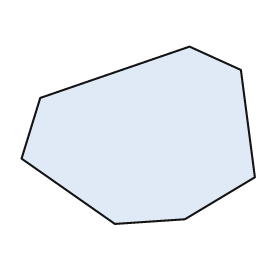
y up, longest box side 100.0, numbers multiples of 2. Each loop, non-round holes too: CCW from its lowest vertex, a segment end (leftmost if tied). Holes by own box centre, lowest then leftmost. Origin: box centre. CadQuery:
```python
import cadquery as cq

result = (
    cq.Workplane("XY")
    .moveTo(-10.0, -38.0)
    .lineTo(20.0, -36.0)
    .lineTo(50.0, -18.0)
    .lineTo(44.0, 28.0)
    .lineTo(22.0, 38.0)
    .lineTo(-42.0, 16.0)
    .lineTo(-50.0, -10.0)
    .close()
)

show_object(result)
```